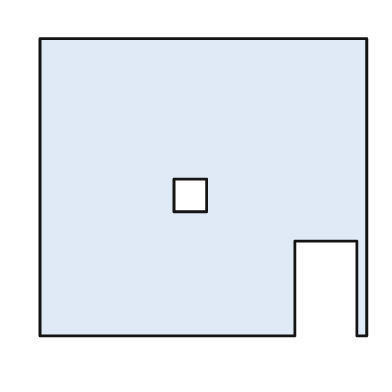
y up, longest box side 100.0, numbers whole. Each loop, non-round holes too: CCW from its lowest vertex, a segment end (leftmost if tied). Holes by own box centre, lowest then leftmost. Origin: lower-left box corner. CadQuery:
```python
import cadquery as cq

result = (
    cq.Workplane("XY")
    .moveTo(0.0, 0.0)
    .lineTo(78.0, 0.0)
    .lineTo(78.0, 29.0)
    .lineTo(97.0, 29.0)
    .lineTo(97.0, 0.0)
    .lineTo(100.0, 0.0)
    .lineTo(100.0, 91.0)
    .lineTo(0.0, 91.0)
    .close()
    .moveTo(41.0, 38.0)
    .lineTo(51.0, 38.0)
    .lineTo(51.0, 48.0)
    .lineTo(41.0, 48.0)
    .close()
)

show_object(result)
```